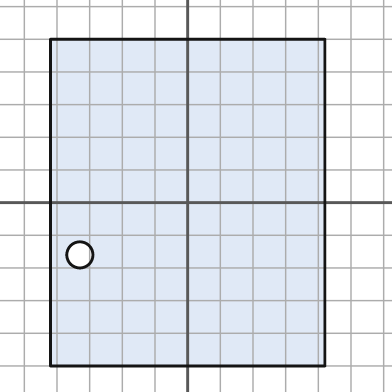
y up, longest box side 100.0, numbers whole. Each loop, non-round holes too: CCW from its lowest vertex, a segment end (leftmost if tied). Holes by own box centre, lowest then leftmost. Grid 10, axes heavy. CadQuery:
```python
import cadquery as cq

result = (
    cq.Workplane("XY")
    .moveTo(-42.0, -50.0)
    .lineTo(42.0, -50.0)
    .lineTo(42.0, 50.0)
    .lineTo(-42.0, 50.0)
    .close()
    .moveTo(-33.0, -16.0)
    .circle(4.0)
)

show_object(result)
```